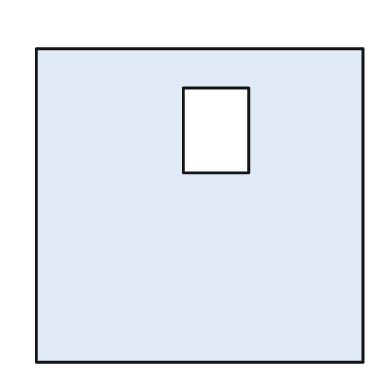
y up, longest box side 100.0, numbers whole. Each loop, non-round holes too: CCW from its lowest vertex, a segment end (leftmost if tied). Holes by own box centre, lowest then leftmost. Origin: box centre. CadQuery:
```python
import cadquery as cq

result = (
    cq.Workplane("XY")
    .moveTo(-50.0, -48.0)
    .lineTo(50.0, -48.0)
    .lineTo(50.0, 48.0)
    .lineTo(-50.0, 48.0)
    .close()
    .moveTo(-5.0, 10.0)
    .lineTo(15.0, 10.0)
    .lineTo(15.0, 36.0)
    .lineTo(-5.0, 36.0)
    .close()
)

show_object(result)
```